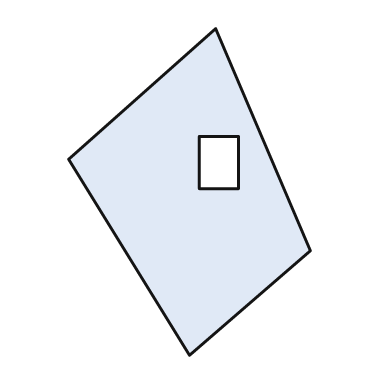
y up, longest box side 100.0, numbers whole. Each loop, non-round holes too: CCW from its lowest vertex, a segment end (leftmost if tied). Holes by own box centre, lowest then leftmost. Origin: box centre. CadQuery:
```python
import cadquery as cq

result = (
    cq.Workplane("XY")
    .moveTo(0.0, -50.0)
    .lineTo(37.0, -18.0)
    .lineTo(8.0, 50.0)
    .lineTo(-37.0, 10.0)
    .close()
    .moveTo(3.0, 1.0)
    .lineTo(15.0, 1.0)
    .lineTo(15.0, 17.0)
    .lineTo(3.0, 17.0)
    .close()
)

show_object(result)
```